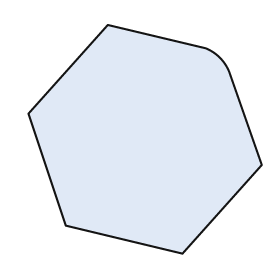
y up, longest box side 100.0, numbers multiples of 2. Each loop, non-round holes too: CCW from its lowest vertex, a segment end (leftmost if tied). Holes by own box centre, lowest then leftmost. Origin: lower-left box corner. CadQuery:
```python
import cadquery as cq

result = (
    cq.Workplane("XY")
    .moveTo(66.0, 0.0)
    .lineTo(100.0, 38.0)
    .lineTo(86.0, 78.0)
    .threePointArc((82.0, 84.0), (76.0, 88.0))
    .lineTo(34.0, 98.0)
    .lineTo(0.0, 60.0)
    .lineTo(16.0, 12.0)
    .close()
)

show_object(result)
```